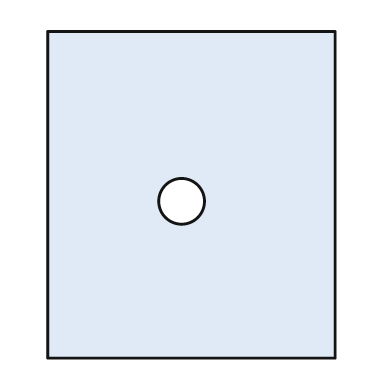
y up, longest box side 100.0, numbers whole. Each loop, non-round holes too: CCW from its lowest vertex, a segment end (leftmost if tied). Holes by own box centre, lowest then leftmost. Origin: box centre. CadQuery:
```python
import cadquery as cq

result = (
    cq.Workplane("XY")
    .moveTo(-44.0, -50.0)
    .lineTo(44.0, -50.0)
    .lineTo(44.0, 50.0)
    .lineTo(-44.0, 50.0)
    .close()
    .moveTo(-3.0, -2.0)
    .circle(7.0)
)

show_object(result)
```